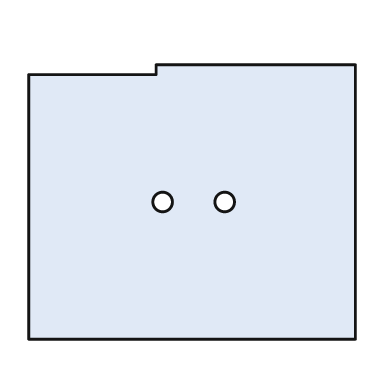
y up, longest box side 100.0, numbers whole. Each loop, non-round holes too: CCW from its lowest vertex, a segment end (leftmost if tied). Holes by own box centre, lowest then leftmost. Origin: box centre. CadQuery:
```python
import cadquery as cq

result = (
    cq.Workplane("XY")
    .moveTo(-50.0, -42.0)
    .lineTo(50.0, -42.0)
    .lineTo(50.0, 42.0)
    .lineTo(-11.0, 42.0)
    .lineTo(-11.0, 39.0)
    .lineTo(-50.0, 39.0)
    .close()
    .moveTo(-9.0, 0.0)
    .circle(3.0)
    .moveTo(10.0, 0.0)
    .circle(3.0)
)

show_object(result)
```